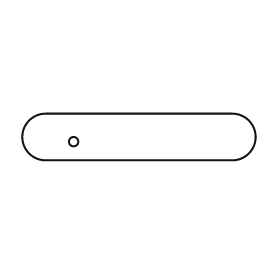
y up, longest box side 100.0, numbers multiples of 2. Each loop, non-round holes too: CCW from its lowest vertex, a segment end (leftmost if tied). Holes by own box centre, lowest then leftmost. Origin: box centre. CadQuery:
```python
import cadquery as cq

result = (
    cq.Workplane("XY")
    .moveTo(-40.0, -10.0)
    .lineTo(40.0, -10.0)
    .threePointArc((50.0, 0.0), (40.0, 10.0))
    .lineTo(-40.0, 10.0)
    .threePointArc((-50.0, 0.0), (-40.0, -10.0))
    .close()
    .moveTo(-28.0, -2.0)
    .circle(2.0)
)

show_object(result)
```